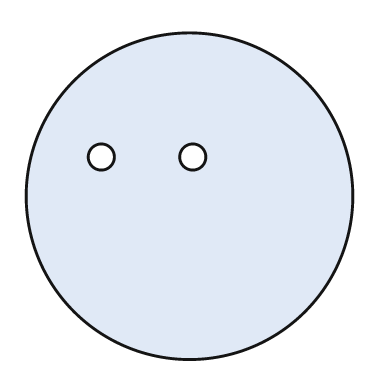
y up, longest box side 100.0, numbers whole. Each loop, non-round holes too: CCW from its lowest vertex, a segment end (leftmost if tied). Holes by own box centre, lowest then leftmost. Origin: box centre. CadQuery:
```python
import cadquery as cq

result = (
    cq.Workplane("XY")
    .moveTo(0.0, 0.0)
    .circle(50.0)
    .moveTo(-27.0, 12.0)
    .circle(4.0)
    .moveTo(1.0, 12.0)
    .circle(4.0)
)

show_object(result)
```